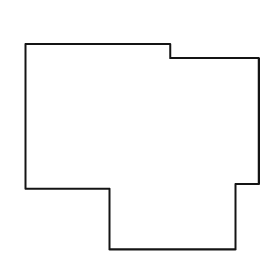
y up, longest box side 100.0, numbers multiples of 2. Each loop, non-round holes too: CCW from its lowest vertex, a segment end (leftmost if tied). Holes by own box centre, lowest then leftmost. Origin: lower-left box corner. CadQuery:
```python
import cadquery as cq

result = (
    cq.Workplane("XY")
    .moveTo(36.0, 0.0)
    .lineTo(90.0, 0.0)
    .lineTo(90.0, 28.0)
    .lineTo(100.0, 28.0)
    .lineTo(100.0, 82.0)
    .lineTo(62.0, 82.0)
    .lineTo(62.0, 88.0)
    .lineTo(0.0, 88.0)
    .lineTo(0.0, 26.0)
    .lineTo(36.0, 26.0)
    .close()
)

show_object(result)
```